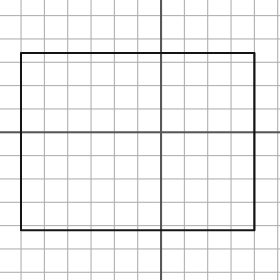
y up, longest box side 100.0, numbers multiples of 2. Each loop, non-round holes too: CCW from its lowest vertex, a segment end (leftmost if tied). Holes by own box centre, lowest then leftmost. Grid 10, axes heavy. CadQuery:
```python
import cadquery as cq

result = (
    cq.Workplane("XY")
    .moveTo(-60.0, -42.0)
    .lineTo(40.0, -42.0)
    .lineTo(40.0, 34.0)
    .lineTo(-60.0, 34.0)
    .close()
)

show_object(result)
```